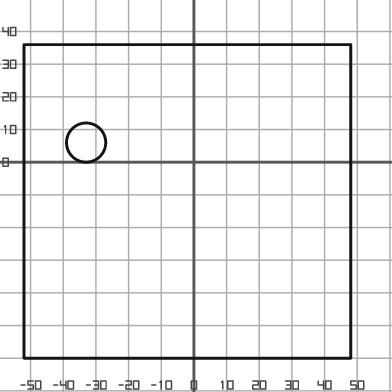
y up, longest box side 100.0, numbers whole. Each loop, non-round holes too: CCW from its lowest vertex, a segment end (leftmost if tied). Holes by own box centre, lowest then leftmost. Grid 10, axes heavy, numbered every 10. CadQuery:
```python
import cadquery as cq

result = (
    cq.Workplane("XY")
    .moveTo(-52.0, -60.0)
    .lineTo(48.0, -60.0)
    .lineTo(48.0, 36.0)
    .lineTo(-52.0, 36.0)
    .close()
    .moveTo(-33.0, 6.0)
    .circle(6.0)
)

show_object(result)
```